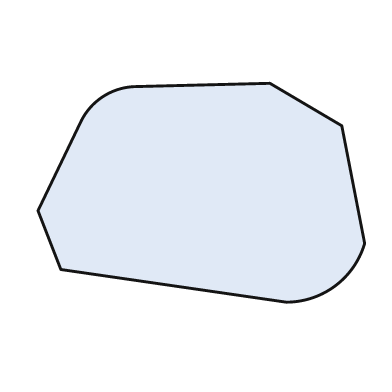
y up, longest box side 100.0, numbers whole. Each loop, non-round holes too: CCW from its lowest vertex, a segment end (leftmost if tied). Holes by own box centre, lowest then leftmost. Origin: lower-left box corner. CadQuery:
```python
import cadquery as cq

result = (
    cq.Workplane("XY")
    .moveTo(76.0, 0.0)
    .threePointArc((91.0, 5.0), (100.0, 18.0))
    .lineTo(93.0, 54.0)
    .lineTo(71.0, 67.0)
    .lineTo(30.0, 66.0)
    .threePointArc((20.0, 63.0), (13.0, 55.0))
    .lineTo(0.0, 28.0)
    .lineTo(7.0, 10.0)
    .close()
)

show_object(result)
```